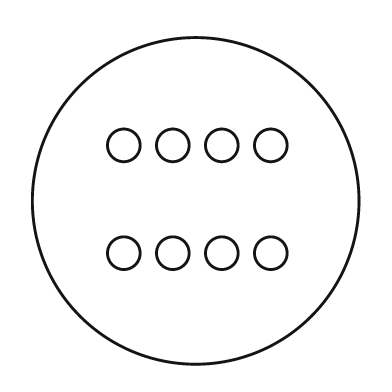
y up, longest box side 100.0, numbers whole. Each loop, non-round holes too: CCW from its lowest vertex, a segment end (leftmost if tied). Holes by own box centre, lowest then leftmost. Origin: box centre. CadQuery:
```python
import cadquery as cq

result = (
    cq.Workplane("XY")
    .moveTo(0.0, 0.0)
    .circle(50.0)
    .moveTo(-22.0, -16.0)
    .circle(5.0)
    .moveTo(-7.0, -16.0)
    .circle(5.0)
    .moveTo(8.0, -16.0)
    .circle(5.0)
    .moveTo(23.0, -16.0)
    .circle(5.0)
    .moveTo(-22.0, 17.0)
    .circle(5.0)
    .moveTo(-7.0, 17.0)
    .circle(5.0)
    .moveTo(8.0, 17.0)
    .circle(5.0)
    .moveTo(23.0, 17.0)
    .circle(5.0)
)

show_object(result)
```